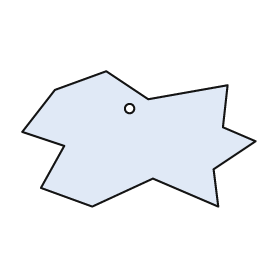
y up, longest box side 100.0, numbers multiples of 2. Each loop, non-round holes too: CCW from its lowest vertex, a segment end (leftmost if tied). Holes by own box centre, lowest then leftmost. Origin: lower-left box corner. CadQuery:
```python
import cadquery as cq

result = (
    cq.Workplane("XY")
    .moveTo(30.0, 0.0)
    .lineTo(56.0, 12.0)
    .lineTo(84.0, 0.0)
    .lineTo(82.0, 16.0)
    .lineTo(100.0, 28.0)
    .lineTo(86.0, 34.0)
    .lineTo(88.0, 52.0)
    .lineTo(54.0, 46.0)
    .lineTo(36.0, 58.0)
    .lineTo(14.0, 50.0)
    .lineTo(0.0, 32.0)
    .lineTo(18.0, 26.0)
    .lineTo(8.0, 8.0)
    .close()
    .moveTo(46.0, 42.0)
    .circle(2.0)
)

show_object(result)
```